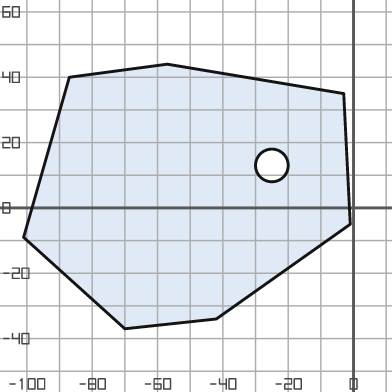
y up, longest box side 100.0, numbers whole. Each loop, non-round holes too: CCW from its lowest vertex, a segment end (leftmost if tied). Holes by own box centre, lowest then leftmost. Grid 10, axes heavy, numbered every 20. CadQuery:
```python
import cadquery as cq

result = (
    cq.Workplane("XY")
    .moveTo(-70.0, -37.0)
    .lineTo(-42.0, -34.0)
    .lineTo(-1.0, -5.0)
    .lineTo(-3.0, 35.0)
    .lineTo(-57.0, 44.0)
    .lineTo(-87.0, 40.0)
    .lineTo(-101.0, -9.0)
    .close()
    .moveTo(-25.0, 13.0)
    .circle(5.0)
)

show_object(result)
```